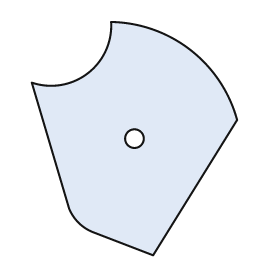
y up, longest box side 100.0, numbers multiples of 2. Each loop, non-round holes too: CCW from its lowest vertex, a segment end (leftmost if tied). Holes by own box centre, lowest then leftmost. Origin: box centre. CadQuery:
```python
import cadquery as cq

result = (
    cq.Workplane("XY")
    .moveTo(8.0, -50.0)
    .lineTo(44.0, 8.0)
    .threePointArc((24.0, 38.0), (-10.0, 50.0))
    .threePointArc((-20.0, 28.0), (-44.0, 24.0))
    .lineTo(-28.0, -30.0)
    .threePointArc((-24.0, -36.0), (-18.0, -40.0))
    .close()
    .moveTo(0.0, 0.0)
    .circle(4.0)
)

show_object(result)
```